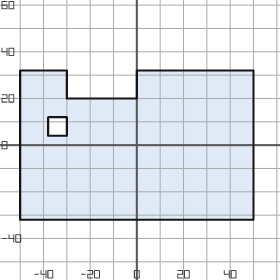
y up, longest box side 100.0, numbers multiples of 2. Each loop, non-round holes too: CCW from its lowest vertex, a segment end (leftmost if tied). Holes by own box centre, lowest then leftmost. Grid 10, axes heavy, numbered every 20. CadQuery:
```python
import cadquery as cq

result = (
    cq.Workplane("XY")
    .moveTo(-50.0, -32.0)
    .lineTo(50.0, -32.0)
    .lineTo(50.0, 32.0)
    .lineTo(0.0, 32.0)
    .lineTo(0.0, 20.0)
    .lineTo(-30.0, 20.0)
    .lineTo(-30.0, 32.0)
    .lineTo(-50.0, 32.0)
    .close()
    .moveTo(-38.0, 4.0)
    .lineTo(-30.0, 4.0)
    .lineTo(-30.0, 12.0)
    .lineTo(-38.0, 12.0)
    .close()
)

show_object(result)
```